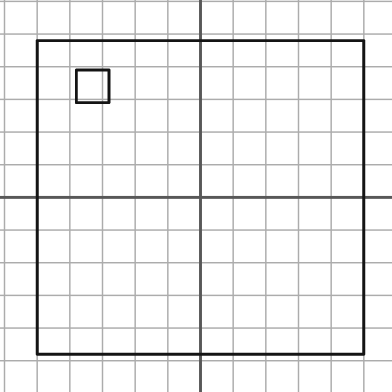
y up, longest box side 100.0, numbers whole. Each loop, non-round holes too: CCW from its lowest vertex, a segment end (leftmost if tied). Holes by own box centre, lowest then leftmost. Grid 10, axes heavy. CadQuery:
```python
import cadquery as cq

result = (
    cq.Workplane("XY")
    .moveTo(-50.0, -48.0)
    .lineTo(50.0, -48.0)
    .lineTo(50.0, 48.0)
    .lineTo(-50.0, 48.0)
    .close()
    .moveTo(-38.0, 29.0)
    .lineTo(-28.0, 29.0)
    .lineTo(-28.0, 39.0)
    .lineTo(-38.0, 39.0)
    .close()
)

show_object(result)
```